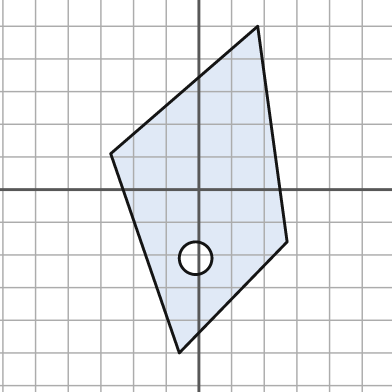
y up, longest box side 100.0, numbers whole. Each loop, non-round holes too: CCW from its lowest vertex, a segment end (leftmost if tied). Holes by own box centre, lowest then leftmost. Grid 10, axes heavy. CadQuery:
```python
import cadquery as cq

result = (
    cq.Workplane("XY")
    .moveTo(-6.0, -50.0)
    .lineTo(27.0, -16.0)
    .lineTo(18.0, 50.0)
    .lineTo(-27.0, 11.0)
    .close()
    .moveTo(-1.0, -21.0)
    .circle(5.0)
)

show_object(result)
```